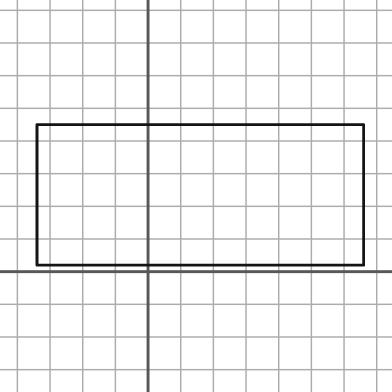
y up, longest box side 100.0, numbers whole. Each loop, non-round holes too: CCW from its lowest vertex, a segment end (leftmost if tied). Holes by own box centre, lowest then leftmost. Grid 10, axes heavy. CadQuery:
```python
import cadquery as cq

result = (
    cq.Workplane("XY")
    .moveTo(-34.0, 2.0)
    .lineTo(66.0, 2.0)
    .lineTo(66.0, 45.0)
    .lineTo(-34.0, 45.0)
    .close()
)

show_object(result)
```